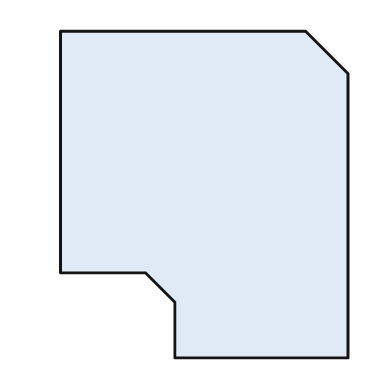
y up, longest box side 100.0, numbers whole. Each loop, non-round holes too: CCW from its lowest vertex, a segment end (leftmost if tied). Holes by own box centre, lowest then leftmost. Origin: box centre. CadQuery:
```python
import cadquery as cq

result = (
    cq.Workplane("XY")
    .moveTo(-9.0, -50.0)
    .lineTo(44.0, -50.0)
    .lineTo(44.0, 37.0)
    .lineTo(31.0, 50.0)
    .lineTo(-44.0, 50.0)
    .lineTo(-44.0, -24.0)
    .lineTo(-18.0, -24.0)
    .lineTo(-9.0, -33.0)
    .close()
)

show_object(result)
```